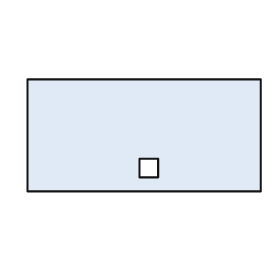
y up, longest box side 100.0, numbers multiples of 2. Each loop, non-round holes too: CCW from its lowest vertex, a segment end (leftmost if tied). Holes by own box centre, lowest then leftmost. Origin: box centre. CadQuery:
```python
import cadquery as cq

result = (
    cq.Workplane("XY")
    .moveTo(-50.0, -24.0)
    .lineTo(50.0, -24.0)
    .lineTo(50.0, 24.0)
    .lineTo(-50.0, 24.0)
    .close()
    .moveTo(-2.0, -18.0)
    .lineTo(6.0, -18.0)
    .lineTo(6.0, -10.0)
    .lineTo(-2.0, -10.0)
    .close()
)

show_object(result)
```